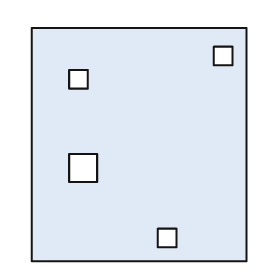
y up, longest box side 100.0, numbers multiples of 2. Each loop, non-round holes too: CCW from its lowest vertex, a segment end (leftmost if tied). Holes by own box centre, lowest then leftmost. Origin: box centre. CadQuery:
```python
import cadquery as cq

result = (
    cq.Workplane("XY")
    .moveTo(-46.0, -50.0)
    .lineTo(46.0, -50.0)
    .lineTo(46.0, 50.0)
    .lineTo(-46.0, 50.0)
    .close()
    .moveTo(8.0, -44.0)
    .lineTo(16.0, -44.0)
    .lineTo(16.0, -36.0)
    .lineTo(8.0, -36.0)
    .close()
    .moveTo(-30.0, -16.0)
    .lineTo(-18.0, -16.0)
    .lineTo(-18.0, -4.0)
    .lineTo(-30.0, -4.0)
    .close()
    .moveTo(-30.0, 24.0)
    .lineTo(-22.0, 24.0)
    .lineTo(-22.0, 32.0)
    .lineTo(-30.0, 32.0)
    .close()
    .moveTo(32.0, 34.0)
    .lineTo(40.0, 34.0)
    .lineTo(40.0, 42.0)
    .lineTo(32.0, 42.0)
    .close()
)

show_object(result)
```